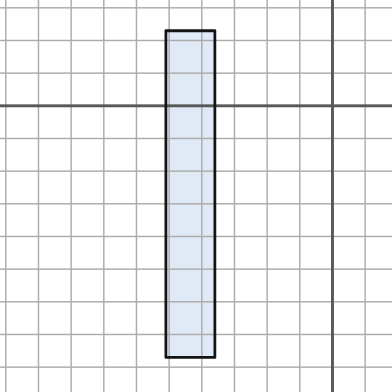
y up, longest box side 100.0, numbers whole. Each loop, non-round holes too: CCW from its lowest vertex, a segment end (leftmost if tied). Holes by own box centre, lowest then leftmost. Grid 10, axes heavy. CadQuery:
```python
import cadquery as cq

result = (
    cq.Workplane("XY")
    .moveTo(-51.0, -77.0)
    .lineTo(-36.0, -77.0)
    .lineTo(-36.0, 23.0)
    .lineTo(-51.0, 23.0)
    .close()
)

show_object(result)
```